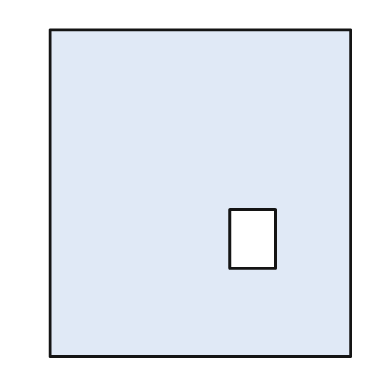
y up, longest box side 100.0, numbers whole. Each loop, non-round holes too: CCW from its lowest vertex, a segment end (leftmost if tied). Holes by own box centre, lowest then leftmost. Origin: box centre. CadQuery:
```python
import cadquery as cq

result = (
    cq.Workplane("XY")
    .moveTo(-46.0, -50.0)
    .lineTo(46.0, -50.0)
    .lineTo(46.0, 50.0)
    .lineTo(-46.0, 50.0)
    .close()
    .moveTo(9.0, -23.0)
    .lineTo(23.0, -23.0)
    .lineTo(23.0, -5.0)
    .lineTo(9.0, -5.0)
    .close()
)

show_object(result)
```